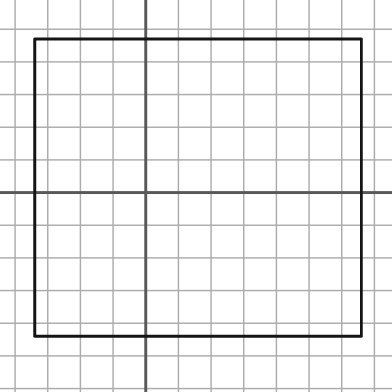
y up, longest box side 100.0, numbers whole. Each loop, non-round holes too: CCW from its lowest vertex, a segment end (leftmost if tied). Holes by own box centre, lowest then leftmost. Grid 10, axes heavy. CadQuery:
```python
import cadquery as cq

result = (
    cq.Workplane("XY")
    .moveTo(-34.0, -44.0)
    .lineTo(66.0, -44.0)
    .lineTo(66.0, 47.0)
    .lineTo(-34.0, 47.0)
    .close()
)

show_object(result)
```